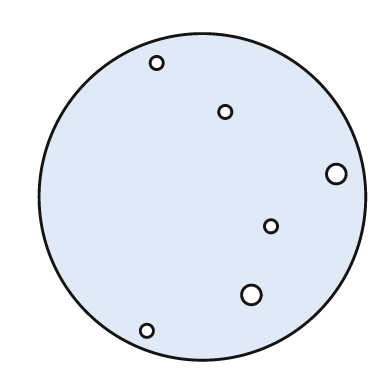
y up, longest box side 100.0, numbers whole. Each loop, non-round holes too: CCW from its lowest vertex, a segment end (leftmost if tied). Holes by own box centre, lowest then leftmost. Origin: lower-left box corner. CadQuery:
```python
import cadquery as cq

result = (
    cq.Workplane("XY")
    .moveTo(50.0, 50.0)
    .circle(50.0)
    .moveTo(33.0, 9.0)
    .circle(2.0)
    .moveTo(65.0, 20.0)
    .circle(3.0)
    .moveTo(71.0, 41.0)
    .circle(2.0)
    .moveTo(91.0, 57.0)
    .circle(3.0)
    .moveTo(57.0, 76.0)
    .circle(2.0)
    .moveTo(36.0, 91.0)
    .circle(2.0)
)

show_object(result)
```